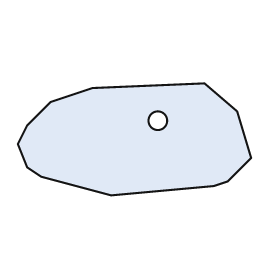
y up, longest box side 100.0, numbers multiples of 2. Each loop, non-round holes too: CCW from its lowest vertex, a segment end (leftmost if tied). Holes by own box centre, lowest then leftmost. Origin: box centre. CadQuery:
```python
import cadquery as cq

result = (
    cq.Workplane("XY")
    .moveTo(-10.0, -24.0)
    .lineTo(34.0, -20.0)
    .lineTo(40.0, -18.0)
    .lineTo(50.0, -8.0)
    .lineTo(44.0, 12.0)
    .lineTo(30.0, 24.0)
    .lineTo(-18.0, 22.0)
    .lineTo(-36.0, 16.0)
    .lineTo(-46.0, 6.0)
    .lineTo(-50.0, -2.0)
    .lineTo(-46.0, -12.0)
    .lineTo(-40.0, -16.0)
    .close()
    .moveTo(10.0, 8.0)
    .circle(4.0)
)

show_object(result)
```